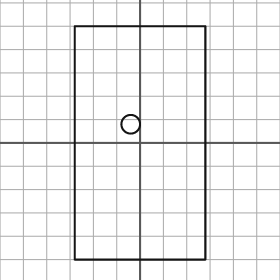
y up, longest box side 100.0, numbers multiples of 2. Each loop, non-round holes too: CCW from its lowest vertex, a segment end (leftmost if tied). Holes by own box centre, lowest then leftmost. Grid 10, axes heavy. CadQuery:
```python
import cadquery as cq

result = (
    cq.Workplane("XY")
    .moveTo(-28.0, -50.0)
    .lineTo(28.0, -50.0)
    .lineTo(28.0, 50.0)
    .lineTo(-28.0, 50.0)
    .close()
    .moveTo(-4.0, 8.0)
    .circle(4.0)
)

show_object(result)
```